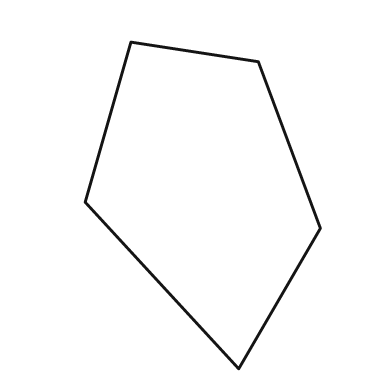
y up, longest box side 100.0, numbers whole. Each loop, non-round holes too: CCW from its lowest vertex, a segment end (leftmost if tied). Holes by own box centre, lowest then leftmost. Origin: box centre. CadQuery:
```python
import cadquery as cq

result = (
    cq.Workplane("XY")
    .moveTo(11.0, -50.0)
    .lineTo(36.0, -7.0)
    .lineTo(17.0, 44.0)
    .lineTo(-22.0, 50.0)
    .lineTo(-36.0, 1.0)
    .close()
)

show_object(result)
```